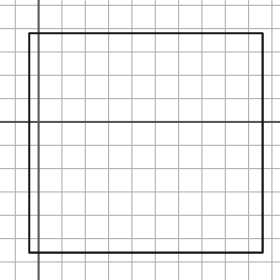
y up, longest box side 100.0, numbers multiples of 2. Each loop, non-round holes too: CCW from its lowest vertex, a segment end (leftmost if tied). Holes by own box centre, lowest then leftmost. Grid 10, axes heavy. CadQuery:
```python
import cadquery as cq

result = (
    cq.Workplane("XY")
    .moveTo(-4.0, -56.0)
    .lineTo(96.0, -56.0)
    .lineTo(96.0, 38.0)
    .lineTo(-4.0, 38.0)
    .close()
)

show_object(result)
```